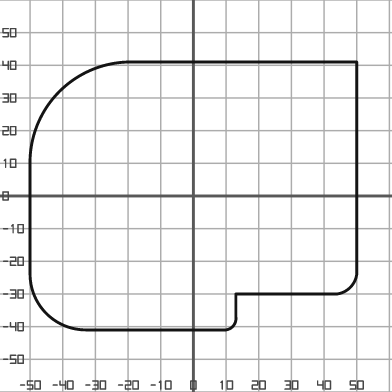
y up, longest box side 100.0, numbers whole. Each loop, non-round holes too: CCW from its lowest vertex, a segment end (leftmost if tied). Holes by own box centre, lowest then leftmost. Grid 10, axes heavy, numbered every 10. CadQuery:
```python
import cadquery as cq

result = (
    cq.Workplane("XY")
    .moveTo(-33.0, -41.0)
    .lineTo(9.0, -41.0)
    .threePointArc((12.0, -40.0), (13.0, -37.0))
    .lineTo(13.0, -30.0)
    .lineTo(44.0, -30.0)
    .threePointArc((48.0, -28.0), (50.0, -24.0))
    .lineTo(50.0, 41.0)
    .lineTo(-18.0, 41.0)
    .threePointArc((-41.0, 32.0), (-50.0, 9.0))
    .lineTo(-50.0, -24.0)
    .threePointArc((-45.0, -36.0), (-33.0, -41.0))
    .close()
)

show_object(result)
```